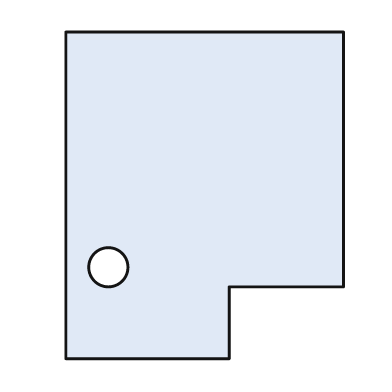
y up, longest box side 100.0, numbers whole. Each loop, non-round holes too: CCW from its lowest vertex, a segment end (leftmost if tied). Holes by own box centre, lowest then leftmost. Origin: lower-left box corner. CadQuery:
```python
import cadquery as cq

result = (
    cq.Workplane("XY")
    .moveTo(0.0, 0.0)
    .lineTo(50.0, 0.0)
    .lineTo(50.0, 22.0)
    .lineTo(85.0, 22.0)
    .lineTo(85.0, 100.0)
    .lineTo(0.0, 100.0)
    .close()
    .moveTo(13.0, 28.0)
    .circle(6.0)
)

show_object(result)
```